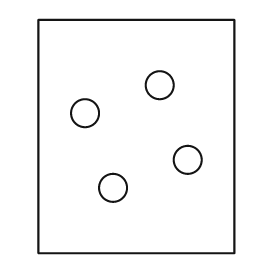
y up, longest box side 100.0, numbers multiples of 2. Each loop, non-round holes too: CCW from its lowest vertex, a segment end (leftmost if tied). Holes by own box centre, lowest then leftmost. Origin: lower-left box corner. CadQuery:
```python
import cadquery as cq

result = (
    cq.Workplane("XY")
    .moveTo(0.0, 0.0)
    .lineTo(84.0, 0.0)
    .lineTo(84.0, 100.0)
    .lineTo(0.0, 100.0)
    .close()
    .moveTo(32.0, 28.0)
    .circle(6.0)
    .moveTo(64.0, 40.0)
    .circle(6.0)
    .moveTo(20.0, 60.0)
    .circle(6.0)
    .moveTo(52.0, 72.0)
    .circle(6.0)
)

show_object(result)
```